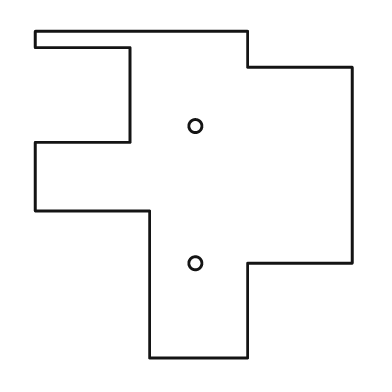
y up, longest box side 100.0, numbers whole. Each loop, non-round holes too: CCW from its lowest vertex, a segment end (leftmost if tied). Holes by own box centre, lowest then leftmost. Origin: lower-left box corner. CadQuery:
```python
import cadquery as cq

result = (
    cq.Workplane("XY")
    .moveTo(35.0, 0.0)
    .lineTo(65.0, 0.0)
    .lineTo(65.0, 29.0)
    .lineTo(97.0, 29.0)
    .lineTo(97.0, 89.0)
    .lineTo(65.0, 89.0)
    .lineTo(65.0, 100.0)
    .lineTo(0.0, 100.0)
    .lineTo(0.0, 95.0)
    .lineTo(29.0, 95.0)
    .lineTo(29.0, 66.0)
    .lineTo(0.0, 66.0)
    .lineTo(0.0, 45.0)
    .lineTo(35.0, 45.0)
    .close()
    .moveTo(49.0, 29.0)
    .circle(2.0)
    .moveTo(49.0, 71.0)
    .circle(2.0)
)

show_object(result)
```